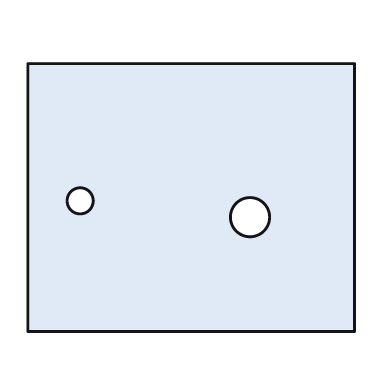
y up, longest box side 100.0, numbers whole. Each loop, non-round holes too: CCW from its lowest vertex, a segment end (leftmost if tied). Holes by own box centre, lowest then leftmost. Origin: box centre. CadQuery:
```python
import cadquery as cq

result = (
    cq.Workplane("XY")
    .moveTo(-50.0, -41.0)
    .lineTo(50.0, -41.0)
    .lineTo(50.0, 41.0)
    .lineTo(-50.0, 41.0)
    .close()
    .moveTo(18.0, -6.0)
    .circle(6.0)
    .moveTo(-34.0, -1.0)
    .circle(4.0)
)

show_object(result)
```